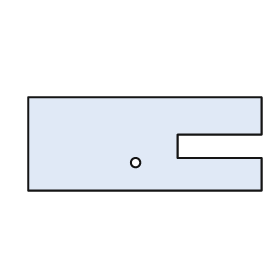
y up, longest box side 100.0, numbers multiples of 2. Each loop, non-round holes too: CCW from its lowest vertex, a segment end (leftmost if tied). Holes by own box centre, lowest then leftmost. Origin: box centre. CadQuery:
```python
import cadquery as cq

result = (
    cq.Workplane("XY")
    .moveTo(-50.0, -20.0)
    .lineTo(50.0, -20.0)
    .lineTo(50.0, -6.0)
    .lineTo(14.0, -6.0)
    .lineTo(14.0, 4.0)
    .lineTo(50.0, 4.0)
    .lineTo(50.0, 20.0)
    .lineTo(-50.0, 20.0)
    .close()
    .moveTo(-4.0, -8.0)
    .circle(2.0)
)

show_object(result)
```